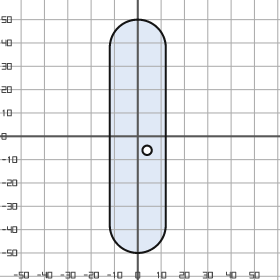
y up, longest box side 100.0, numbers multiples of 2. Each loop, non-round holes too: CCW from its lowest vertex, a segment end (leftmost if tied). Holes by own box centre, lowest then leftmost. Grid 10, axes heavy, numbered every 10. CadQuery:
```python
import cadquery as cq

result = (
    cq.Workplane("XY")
    .moveTo(-12.0, -38.0)
    .threePointArc((0.0, -50.0), (12.0, -38.0))
    .lineTo(12.0, 38.0)
    .threePointArc((0.0, 50.0), (-12.0, 38.0))
    .close()
    .moveTo(4.0, -6.0)
    .circle(2.0)
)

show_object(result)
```